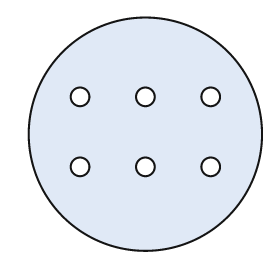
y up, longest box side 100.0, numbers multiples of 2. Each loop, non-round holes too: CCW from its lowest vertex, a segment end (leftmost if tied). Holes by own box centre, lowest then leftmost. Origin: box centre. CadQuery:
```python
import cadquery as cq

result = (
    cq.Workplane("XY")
    .moveTo(0.0, 0.0)
    .circle(50.0)
    .moveTo(-28.0, -14.0)
    .circle(4.0)
    .moveTo(0.0, -14.0)
    .circle(4.0)
    .moveTo(28.0, -14.0)
    .circle(4.0)
    .moveTo(-28.0, 16.0)
    .circle(4.0)
    .moveTo(0.0, 16.0)
    .circle(4.0)
    .moveTo(28.0, 16.0)
    .circle(4.0)
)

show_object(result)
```